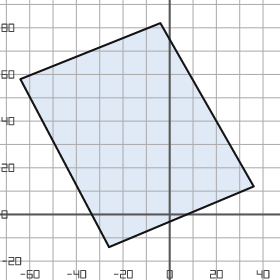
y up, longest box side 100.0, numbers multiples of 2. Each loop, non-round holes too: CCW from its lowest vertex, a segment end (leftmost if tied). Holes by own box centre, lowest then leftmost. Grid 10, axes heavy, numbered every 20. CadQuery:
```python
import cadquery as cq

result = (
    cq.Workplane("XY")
    .moveTo(-26.0, -14.0)
    .lineTo(36.0, 12.0)
    .lineTo(-4.0, 82.0)
    .lineTo(-64.0, 58.0)
    .close()
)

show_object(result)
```